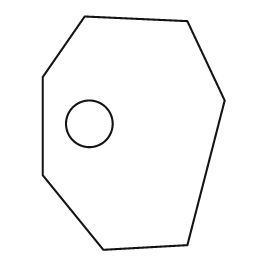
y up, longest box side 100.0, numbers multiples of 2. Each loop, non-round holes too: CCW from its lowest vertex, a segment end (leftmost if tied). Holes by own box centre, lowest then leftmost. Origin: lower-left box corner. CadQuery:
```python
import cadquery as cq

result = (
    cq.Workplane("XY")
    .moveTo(26.0, 0.0)
    .lineTo(62.0, 2.0)
    .lineTo(78.0, 64.0)
    .lineTo(62.0, 98.0)
    .lineTo(18.0, 100.0)
    .lineTo(0.0, 74.0)
    .lineTo(0.0, 32.0)
    .close()
    .moveTo(20.0, 54.0)
    .circle(10.0)
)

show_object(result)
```